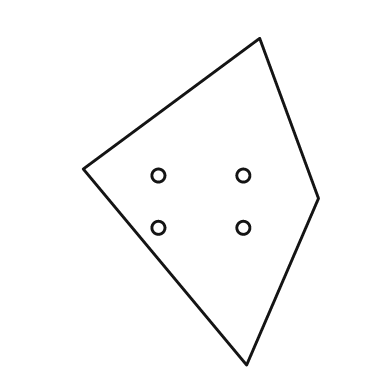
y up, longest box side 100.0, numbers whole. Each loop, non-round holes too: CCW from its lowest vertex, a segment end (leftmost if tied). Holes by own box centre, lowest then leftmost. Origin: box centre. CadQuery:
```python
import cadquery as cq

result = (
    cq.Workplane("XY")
    .moveTo(14.0, -50.0)
    .lineTo(36.0, 1.0)
    .lineTo(18.0, 50.0)
    .lineTo(-36.0, 10.0)
    .close()
    .moveTo(-13.0, -8.0)
    .circle(2.0)
    .moveTo(13.0, -8.0)
    .circle(2.0)
    .moveTo(-13.0, 8.0)
    .circle(2.0)
    .moveTo(13.0, 8.0)
    .circle(2.0)
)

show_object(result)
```